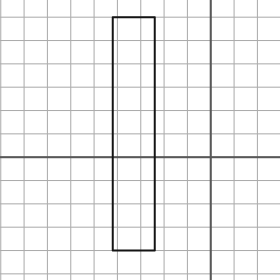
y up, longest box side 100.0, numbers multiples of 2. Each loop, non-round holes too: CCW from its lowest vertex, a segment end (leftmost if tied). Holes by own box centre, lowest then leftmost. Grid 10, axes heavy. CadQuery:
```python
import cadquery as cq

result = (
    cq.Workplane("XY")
    .moveTo(-42.0, -40.0)
    .lineTo(-24.0, -40.0)
    .lineTo(-24.0, 60.0)
    .lineTo(-42.0, 60.0)
    .close()
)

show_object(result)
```